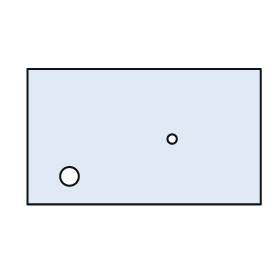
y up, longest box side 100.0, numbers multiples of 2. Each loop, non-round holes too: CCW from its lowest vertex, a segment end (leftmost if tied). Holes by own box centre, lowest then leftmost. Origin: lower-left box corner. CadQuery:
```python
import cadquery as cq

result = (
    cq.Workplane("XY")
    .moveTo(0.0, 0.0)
    .lineTo(100.0, 0.0)
    .lineTo(100.0, 58.0)
    .lineTo(0.0, 58.0)
    .close()
    .moveTo(18.0, 12.0)
    .circle(4.0)
    .moveTo(62.0, 28.0)
    .circle(2.0)
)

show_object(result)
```